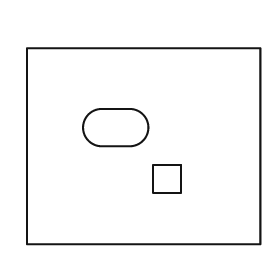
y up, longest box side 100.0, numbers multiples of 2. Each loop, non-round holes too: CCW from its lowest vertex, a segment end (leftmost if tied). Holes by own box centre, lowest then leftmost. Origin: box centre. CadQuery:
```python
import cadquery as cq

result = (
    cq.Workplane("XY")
    .moveTo(-50.0, -42.0)
    .lineTo(50.0, -42.0)
    .lineTo(50.0, 42.0)
    .lineTo(-50.0, 42.0)
    .close()
    .moveTo(4.0, -20.0)
    .lineTo(16.0, -20.0)
    .lineTo(16.0, -8.0)
    .lineTo(4.0, -8.0)
    .close()
    .moveTo(-18.0, 0.0)
    .lineTo(-6.0, 0.0)
    .threePointArc((2.0, 8.0), (-6.0, 16.0))
    .lineTo(-18.0, 16.0)
    .threePointArc((-26.0, 8.0), (-18.0, 0.0))
    .close()
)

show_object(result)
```